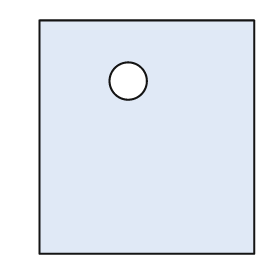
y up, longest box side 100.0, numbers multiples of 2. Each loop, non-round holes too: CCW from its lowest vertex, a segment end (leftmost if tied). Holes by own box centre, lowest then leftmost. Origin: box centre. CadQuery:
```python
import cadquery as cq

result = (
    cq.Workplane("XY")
    .moveTo(-46.0, -50.0)
    .lineTo(46.0, -50.0)
    .lineTo(46.0, 50.0)
    .lineTo(-46.0, 50.0)
    .close()
    .moveTo(-8.0, 24.0)
    .circle(8.0)
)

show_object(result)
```